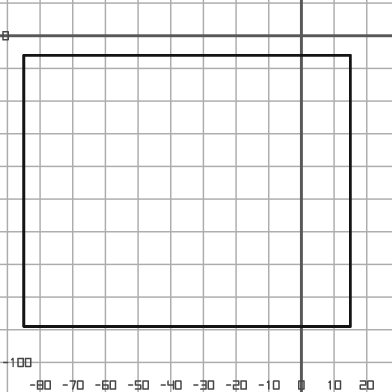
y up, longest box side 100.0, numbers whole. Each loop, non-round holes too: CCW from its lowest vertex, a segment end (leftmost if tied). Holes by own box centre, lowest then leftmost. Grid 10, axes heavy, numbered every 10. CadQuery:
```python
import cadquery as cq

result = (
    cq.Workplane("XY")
    .moveTo(-85.0, -89.0)
    .lineTo(15.0, -89.0)
    .lineTo(15.0, -6.0)
    .lineTo(-85.0, -6.0)
    .close()
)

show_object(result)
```